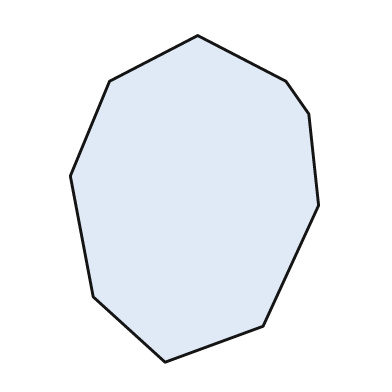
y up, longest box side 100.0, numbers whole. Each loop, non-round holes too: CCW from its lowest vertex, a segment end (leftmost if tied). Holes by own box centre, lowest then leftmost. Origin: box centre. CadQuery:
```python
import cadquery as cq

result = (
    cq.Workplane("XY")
    .moveTo(-9.0, -50.0)
    .lineTo(21.0, -39.0)
    .lineTo(38.0, -2.0)
    .lineTo(35.0, 26.0)
    .lineTo(28.0, 36.0)
    .lineTo(1.0, 50.0)
    .lineTo(-26.0, 36.0)
    .lineTo(-38.0, 7.0)
    .lineTo(-31.0, -30.0)
    .close()
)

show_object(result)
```